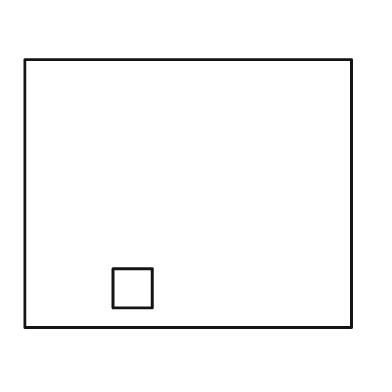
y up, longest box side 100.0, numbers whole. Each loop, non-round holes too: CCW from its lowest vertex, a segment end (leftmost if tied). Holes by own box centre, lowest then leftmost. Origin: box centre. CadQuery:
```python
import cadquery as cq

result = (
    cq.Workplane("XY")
    .moveTo(-50.0, -41.0)
    .lineTo(50.0, -41.0)
    .lineTo(50.0, 41.0)
    .lineTo(-50.0, 41.0)
    .close()
    .moveTo(-23.0, -35.0)
    .lineTo(-11.0, -35.0)
    .lineTo(-11.0, -23.0)
    .lineTo(-23.0, -23.0)
    .close()
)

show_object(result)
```